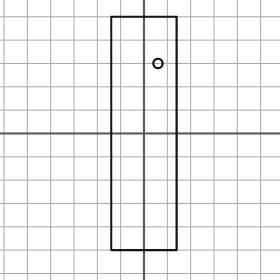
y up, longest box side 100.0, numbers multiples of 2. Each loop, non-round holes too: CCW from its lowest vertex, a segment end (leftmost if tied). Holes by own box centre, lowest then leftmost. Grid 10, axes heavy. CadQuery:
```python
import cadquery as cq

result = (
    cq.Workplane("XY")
    .moveTo(-14.0, -50.0)
    .lineTo(14.0, -50.0)
    .lineTo(14.0, 50.0)
    .lineTo(-14.0, 50.0)
    .close()
    .moveTo(6.0, 30.0)
    .circle(2.0)
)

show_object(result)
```